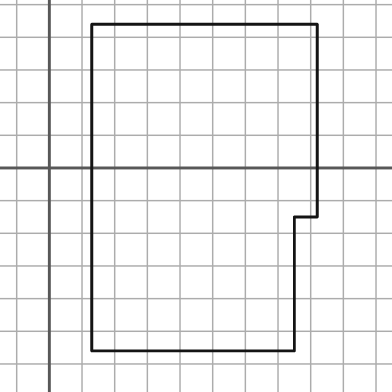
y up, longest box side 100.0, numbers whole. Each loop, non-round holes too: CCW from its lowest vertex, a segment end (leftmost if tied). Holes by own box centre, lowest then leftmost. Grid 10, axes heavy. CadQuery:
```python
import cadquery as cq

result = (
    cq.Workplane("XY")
    .moveTo(13.0, -56.0)
    .lineTo(75.0, -56.0)
    .lineTo(75.0, -15.0)
    .lineTo(82.0, -15.0)
    .lineTo(82.0, 44.0)
    .lineTo(13.0, 44.0)
    .close()
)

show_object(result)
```